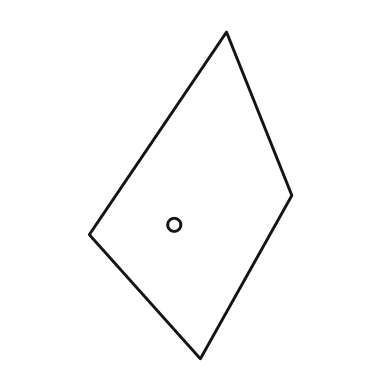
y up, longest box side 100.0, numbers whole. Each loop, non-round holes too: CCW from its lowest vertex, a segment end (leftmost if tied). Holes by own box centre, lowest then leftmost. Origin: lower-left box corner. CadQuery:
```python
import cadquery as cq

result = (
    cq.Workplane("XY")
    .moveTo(34.0, 0.0)
    .lineTo(62.0, 50.0)
    .lineTo(42.0, 100.0)
    .lineTo(0.0, 38.0)
    .close()
    .moveTo(26.0, 41.0)
    .circle(2.0)
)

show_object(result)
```